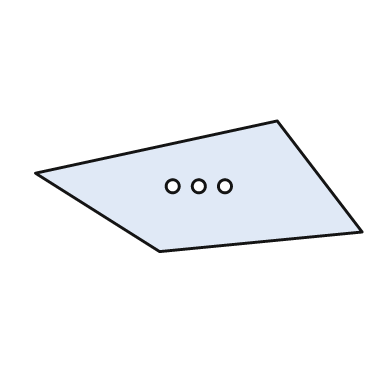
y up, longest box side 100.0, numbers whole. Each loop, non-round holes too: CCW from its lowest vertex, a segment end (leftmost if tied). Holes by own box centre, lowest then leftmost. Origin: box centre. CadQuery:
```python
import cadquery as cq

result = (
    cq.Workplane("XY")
    .moveTo(-12.0, -20.0)
    .lineTo(50.0, -14.0)
    .lineTo(24.0, 20.0)
    .lineTo(-50.0, 4.0)
    .close()
    .moveTo(-8.0, 0.0)
    .circle(2.0)
    .moveTo(0.0, 0.0)
    .circle(2.0)
    .moveTo(8.0, 0.0)
    .circle(2.0)
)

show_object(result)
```